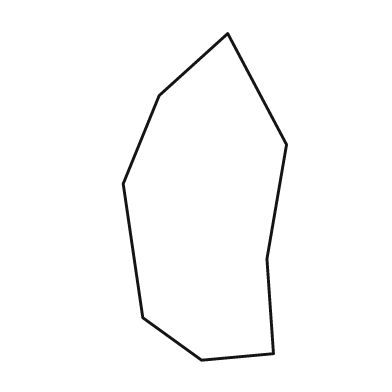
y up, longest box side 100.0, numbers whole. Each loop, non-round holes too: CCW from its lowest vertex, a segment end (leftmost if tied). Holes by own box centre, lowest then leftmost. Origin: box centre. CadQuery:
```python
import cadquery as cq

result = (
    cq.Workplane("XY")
    .moveTo(-1.0, -50.0)
    .lineTo(21.0, -48.0)
    .lineTo(19.0, -19.0)
    .lineTo(25.0, 16.0)
    .lineTo(7.0, 50.0)
    .lineTo(-14.0, 31.0)
    .lineTo(-25.0, 4.0)
    .lineTo(-19.0, -37.0)
    .close()
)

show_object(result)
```